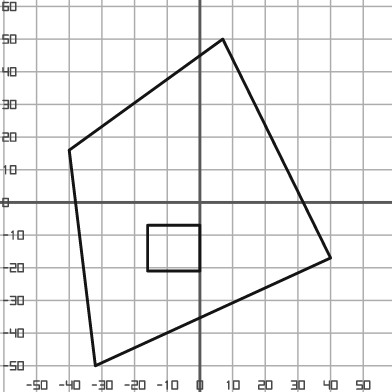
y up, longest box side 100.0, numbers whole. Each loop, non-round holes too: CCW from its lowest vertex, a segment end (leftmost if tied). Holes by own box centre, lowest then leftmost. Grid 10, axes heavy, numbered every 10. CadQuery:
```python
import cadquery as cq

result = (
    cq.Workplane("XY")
    .moveTo(-32.0, -50.0)
    .lineTo(40.0, -17.0)
    .lineTo(7.0, 50.0)
    .lineTo(-40.0, 16.0)
    .close()
    .moveTo(-16.0, -21.0)
    .lineTo(0.0, -21.0)
    .lineTo(0.0, -7.0)
    .lineTo(-16.0, -7.0)
    .close()
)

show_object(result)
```